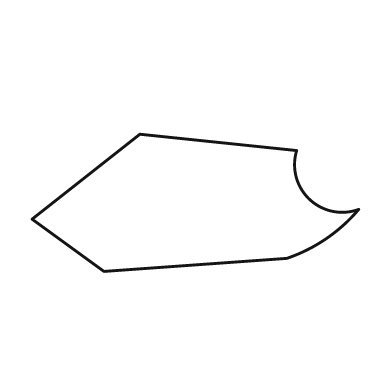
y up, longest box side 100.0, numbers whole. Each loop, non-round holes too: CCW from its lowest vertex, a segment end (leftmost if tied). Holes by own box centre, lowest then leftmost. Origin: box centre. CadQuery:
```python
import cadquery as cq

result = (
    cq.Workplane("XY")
    .moveTo(-28.0, -21.0)
    .lineTo(28.0, -17.0)
    .threePointArc((40.0, -11.0), (50.0, -2.0))
    .threePointArc((35.0, 1.0), (31.0, 16.0))
    .lineTo(-17.0, 21.0)
    .lineTo(-50.0, -5.0)
    .close()
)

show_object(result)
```